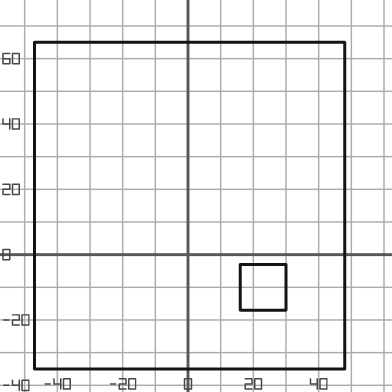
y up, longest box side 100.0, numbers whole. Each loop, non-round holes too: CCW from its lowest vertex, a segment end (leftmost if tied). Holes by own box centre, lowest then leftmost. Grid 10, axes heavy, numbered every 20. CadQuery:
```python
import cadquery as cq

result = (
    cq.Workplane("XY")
    .moveTo(-47.0, -35.0)
    .lineTo(48.0, -35.0)
    .lineTo(48.0, 65.0)
    .lineTo(-47.0, 65.0)
    .close()
    .moveTo(16.0, -17.0)
    .lineTo(30.0, -17.0)
    .lineTo(30.0, -3.0)
    .lineTo(16.0, -3.0)
    .close()
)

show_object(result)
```